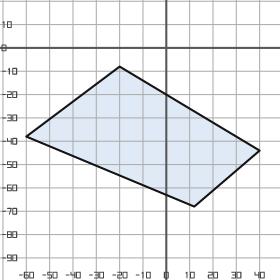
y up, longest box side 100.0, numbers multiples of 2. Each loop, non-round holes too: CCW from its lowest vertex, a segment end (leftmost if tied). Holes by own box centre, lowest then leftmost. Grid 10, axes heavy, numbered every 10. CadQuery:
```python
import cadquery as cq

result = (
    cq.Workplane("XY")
    .moveTo(12.0, -68.0)
    .lineTo(40.0, -44.0)
    .lineTo(-20.0, -8.0)
    .lineTo(-60.0, -38.0)
    .close()
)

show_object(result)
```